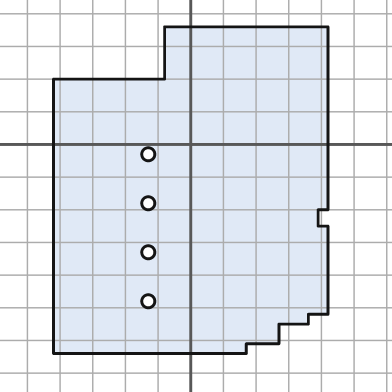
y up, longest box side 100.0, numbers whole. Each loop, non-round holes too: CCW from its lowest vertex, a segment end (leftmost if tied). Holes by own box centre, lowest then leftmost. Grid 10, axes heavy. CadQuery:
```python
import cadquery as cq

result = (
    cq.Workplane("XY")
    .moveTo(-42.0, -64.0)
    .lineTo(17.0, -64.0)
    .lineTo(17.0, -61.0)
    .lineTo(27.0, -61.0)
    .lineTo(27.0, -55.0)
    .lineTo(36.0, -55.0)
    .lineTo(36.0, -52.0)
    .lineTo(42.0, -52.0)
    .lineTo(42.0, -25.0)
    .lineTo(39.0, -25.0)
    .lineTo(39.0, -20.0)
    .lineTo(42.0, -20.0)
    .lineTo(42.0, 36.0)
    .lineTo(-8.0, 36.0)
    .lineTo(-8.0, 20.0)
    .lineTo(-42.0, 20.0)
    .close()
    .moveTo(-13.0, -48.0)
    .circle(2.0)
    .moveTo(-13.0, -33.0)
    .circle(2.0)
    .moveTo(-13.0, -18.0)
    .circle(2.0)
    .moveTo(-13.0, -3.0)
    .circle(2.0)
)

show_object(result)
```